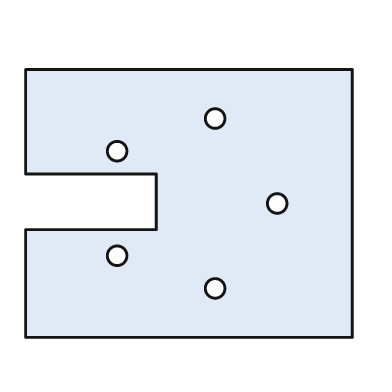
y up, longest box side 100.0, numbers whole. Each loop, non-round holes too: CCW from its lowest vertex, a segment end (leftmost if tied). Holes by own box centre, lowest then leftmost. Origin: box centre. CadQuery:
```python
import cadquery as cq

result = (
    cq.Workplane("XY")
    .moveTo(-50.0, -41.0)
    .lineTo(50.0, -41.0)
    .lineTo(50.0, 41.0)
    .lineTo(-50.0, 41.0)
    .lineTo(-50.0, 9.0)
    .lineTo(-10.0, 9.0)
    .lineTo(-10.0, -8.0)
    .lineTo(-50.0, -8.0)
    .close()
    .moveTo(8.0, -26.0)
    .circle(3.0)
    .moveTo(-22.0, -16.0)
    .circle(3.0)
    .moveTo(27.0, 0.0)
    .circle(3.0)
    .moveTo(-22.0, 16.0)
    .circle(3.0)
    .moveTo(8.0, 26.0)
    .circle(3.0)
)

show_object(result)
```